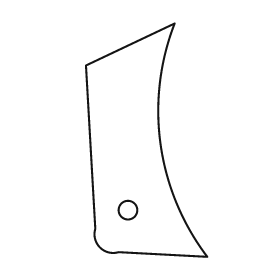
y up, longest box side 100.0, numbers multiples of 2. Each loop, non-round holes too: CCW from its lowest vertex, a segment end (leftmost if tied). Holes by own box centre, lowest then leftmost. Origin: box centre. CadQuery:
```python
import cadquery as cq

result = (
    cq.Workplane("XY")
    .moveTo(26.0, -50.0)
    .threePointArc((6.0, -2.0), (12.0, 50.0))
    .lineTo(-26.0, 32.0)
    .lineTo(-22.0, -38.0)
    .threePointArc((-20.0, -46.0), (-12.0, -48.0))
    .close()
    .moveTo(-8.0, -30.0)
    .circle(4.0)
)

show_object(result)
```